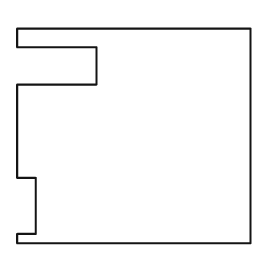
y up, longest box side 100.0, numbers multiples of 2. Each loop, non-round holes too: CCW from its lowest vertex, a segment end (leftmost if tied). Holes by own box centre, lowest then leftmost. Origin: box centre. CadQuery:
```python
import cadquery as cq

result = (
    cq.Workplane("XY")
    .moveTo(-50.0, -46.0)
    .lineTo(50.0, -46.0)
    .lineTo(50.0, 46.0)
    .lineTo(-50.0, 46.0)
    .lineTo(-50.0, 38.0)
    .lineTo(-16.0, 38.0)
    .lineTo(-16.0, 22.0)
    .lineTo(-50.0, 22.0)
    .lineTo(-50.0, -18.0)
    .lineTo(-42.0, -18.0)
    .lineTo(-42.0, -42.0)
    .lineTo(-50.0, -42.0)
    .close()
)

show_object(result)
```